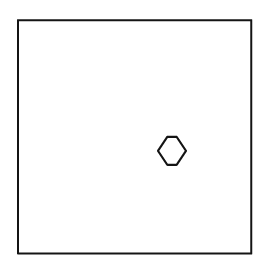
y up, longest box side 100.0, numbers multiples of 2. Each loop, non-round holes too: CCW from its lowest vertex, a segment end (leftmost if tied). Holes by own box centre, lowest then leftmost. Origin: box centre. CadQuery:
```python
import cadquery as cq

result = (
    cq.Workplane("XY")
    .moveTo(-50.0, -50.0)
    .lineTo(50.0, -50.0)
    .lineTo(50.0, 50.0)
    .lineTo(-50.0, 50.0)
    .close()
    .moveTo(14.0, -12.0)
    .lineTo(18.0, -12.0)
    .lineTo(22.0, -6.0)
    .lineTo(18.0, 0.0)
    .lineTo(14.0, 0.0)
    .lineTo(10.0, -6.0)
    .close()
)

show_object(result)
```